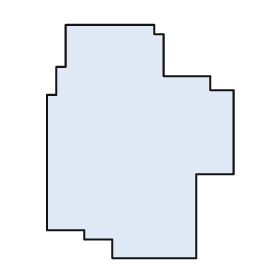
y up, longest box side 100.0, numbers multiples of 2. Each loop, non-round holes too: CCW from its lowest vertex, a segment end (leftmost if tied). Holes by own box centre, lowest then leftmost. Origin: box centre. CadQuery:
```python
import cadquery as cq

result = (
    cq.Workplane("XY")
    .moveTo(-12.0, -50.0)
    .lineTo(24.0, -50.0)
    .lineTo(24.0, -14.0)
    .lineTo(40.0, -14.0)
    .lineTo(40.0, 22.0)
    .lineTo(30.0, 22.0)
    .lineTo(30.0, 28.0)
    .lineTo(10.0, 28.0)
    .lineTo(10.0, 46.0)
    .lineTo(6.0, 46.0)
    .lineTo(6.0, 50.0)
    .lineTo(-32.0, 50.0)
    .lineTo(-32.0, 32.0)
    .lineTo(-36.0, 32.0)
    .lineTo(-36.0, 20.0)
    .lineTo(-40.0, 20.0)
    .lineTo(-40.0, -38.0)
    .lineTo(-24.0, -38.0)
    .lineTo(-24.0, -42.0)
    .lineTo(-12.0, -42.0)
    .close()
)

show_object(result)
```